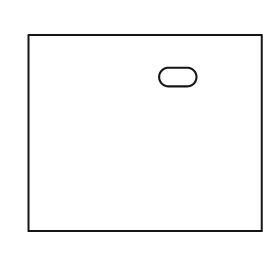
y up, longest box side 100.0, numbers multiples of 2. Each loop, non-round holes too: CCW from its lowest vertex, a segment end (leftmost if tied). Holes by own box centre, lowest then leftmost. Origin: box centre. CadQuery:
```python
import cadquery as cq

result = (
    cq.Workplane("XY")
    .moveTo(-50.0, -42.0)
    .lineTo(50.0, -42.0)
    .lineTo(50.0, 42.0)
    .lineTo(-50.0, 42.0)
    .close()
    .moveTo(10.0, 20.0)
    .lineTo(18.0, 20.0)
    .threePointArc((22.0, 24.0), (18.0, 28.0))
    .lineTo(10.0, 28.0)
    .threePointArc((6.0, 24.0), (10.0, 20.0))
    .close()
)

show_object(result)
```